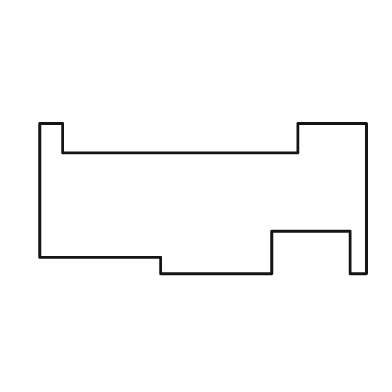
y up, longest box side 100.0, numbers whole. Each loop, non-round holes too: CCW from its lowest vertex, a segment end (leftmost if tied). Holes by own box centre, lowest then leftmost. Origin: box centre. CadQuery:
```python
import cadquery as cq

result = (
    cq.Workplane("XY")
    .moveTo(-13.0, -23.0)
    .lineTo(21.0, -23.0)
    .lineTo(21.0, -10.0)
    .lineTo(45.0, -10.0)
    .lineTo(45.0, -23.0)
    .lineTo(50.0, -23.0)
    .lineTo(50.0, 23.0)
    .lineTo(29.0, 23.0)
    .lineTo(29.0, 14.0)
    .lineTo(-43.0, 14.0)
    .lineTo(-43.0, 23.0)
    .lineTo(-50.0, 23.0)
    .lineTo(-50.0, -18.0)
    .lineTo(-13.0, -18.0)
    .close()
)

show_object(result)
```